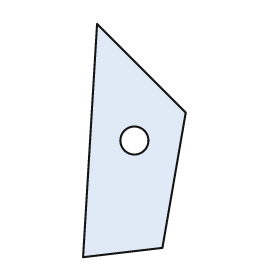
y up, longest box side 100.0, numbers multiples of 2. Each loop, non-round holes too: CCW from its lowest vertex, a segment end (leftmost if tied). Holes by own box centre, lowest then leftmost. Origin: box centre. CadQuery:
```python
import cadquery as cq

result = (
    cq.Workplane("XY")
    .moveTo(-22.0, -50.0)
    .lineTo(12.0, -46.0)
    .lineTo(22.0, 12.0)
    .lineTo(-16.0, 50.0)
    .close()
    .moveTo(0.0, 0.0)
    .circle(6.0)
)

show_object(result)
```